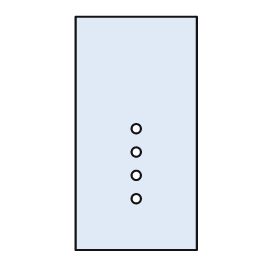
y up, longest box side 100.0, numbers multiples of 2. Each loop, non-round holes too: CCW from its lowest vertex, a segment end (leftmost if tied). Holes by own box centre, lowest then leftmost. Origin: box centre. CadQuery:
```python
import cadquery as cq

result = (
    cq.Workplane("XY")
    .moveTo(-26.0, -50.0)
    .lineTo(26.0, -50.0)
    .lineTo(26.0, 50.0)
    .lineTo(-26.0, 50.0)
    .close()
    .moveTo(0.0, -28.0)
    .circle(2.0)
    .moveTo(0.0, -18.0)
    .circle(2.0)
    .moveTo(0.0, -8.0)
    .circle(2.0)
    .moveTo(0.0, 2.0)
    .circle(2.0)
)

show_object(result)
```